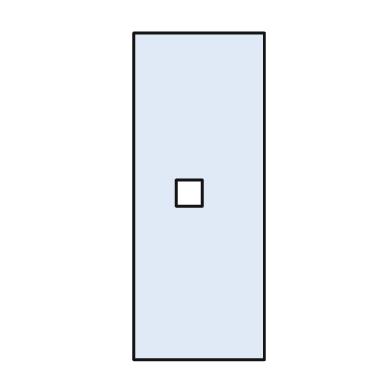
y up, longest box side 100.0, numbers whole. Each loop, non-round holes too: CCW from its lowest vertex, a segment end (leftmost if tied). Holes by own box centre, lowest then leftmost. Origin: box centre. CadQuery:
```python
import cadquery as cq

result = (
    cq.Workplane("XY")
    .moveTo(-20.0, -50.0)
    .lineTo(20.0, -50.0)
    .lineTo(20.0, 50.0)
    .lineTo(-20.0, 50.0)
    .close()
    .moveTo(-7.0, -3.0)
    .lineTo(1.0, -3.0)
    .lineTo(1.0, 5.0)
    .lineTo(-7.0, 5.0)
    .close()
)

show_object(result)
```